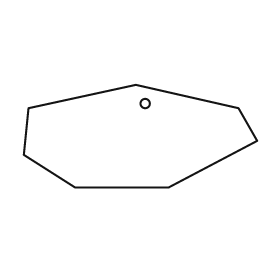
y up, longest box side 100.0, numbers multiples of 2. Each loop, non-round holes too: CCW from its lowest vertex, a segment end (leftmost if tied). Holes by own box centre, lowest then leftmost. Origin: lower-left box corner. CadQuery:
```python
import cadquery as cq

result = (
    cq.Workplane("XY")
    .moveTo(22.0, 0.0)
    .lineTo(62.0, 0.0)
    .lineTo(100.0, 20.0)
    .lineTo(92.0, 34.0)
    .lineTo(48.0, 44.0)
    .lineTo(2.0, 34.0)
    .lineTo(0.0, 14.0)
    .close()
    .moveTo(52.0, 36.0)
    .circle(2.0)
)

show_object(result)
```